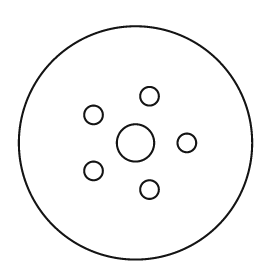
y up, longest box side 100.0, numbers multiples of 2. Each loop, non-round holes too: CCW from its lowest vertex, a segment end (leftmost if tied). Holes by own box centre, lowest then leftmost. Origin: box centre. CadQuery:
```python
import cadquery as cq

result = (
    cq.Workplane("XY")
    .moveTo(0.0, 0.0)
    .circle(50.0)
    .moveTo(6.0, -20.0)
    .circle(4.0)
    .moveTo(-18.0, -12.0)
    .circle(4.0)
    .moveTo(0.0, 0.0)
    .circle(8.0)
    .moveTo(22.0, 0.0)
    .circle(4.0)
    .moveTo(-18.0, 12.0)
    .circle(4.0)
    .moveTo(6.0, 20.0)
    .circle(4.0)
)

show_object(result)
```